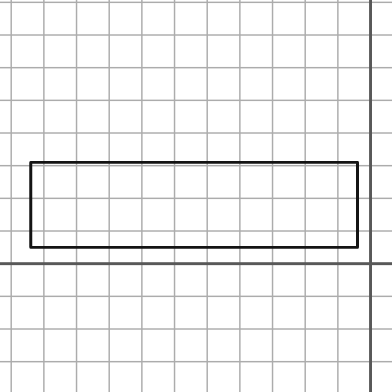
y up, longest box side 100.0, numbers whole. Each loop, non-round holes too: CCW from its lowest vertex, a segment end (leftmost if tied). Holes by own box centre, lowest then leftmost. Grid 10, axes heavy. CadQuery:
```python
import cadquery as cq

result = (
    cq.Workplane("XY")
    .moveTo(-104.0, 5.0)
    .lineTo(-4.0, 5.0)
    .lineTo(-4.0, 31.0)
    .lineTo(-104.0, 31.0)
    .close()
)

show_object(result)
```